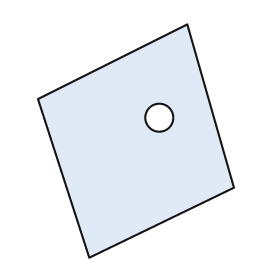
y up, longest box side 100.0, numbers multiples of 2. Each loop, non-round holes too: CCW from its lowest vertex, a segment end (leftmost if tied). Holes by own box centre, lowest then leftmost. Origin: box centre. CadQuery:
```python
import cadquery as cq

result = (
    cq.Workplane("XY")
    .moveTo(-20.0, -50.0)
    .lineTo(42.0, -20.0)
    .lineTo(22.0, 50.0)
    .lineTo(-42.0, 18.0)
    .close()
    .moveTo(10.0, 10.0)
    .circle(6.0)
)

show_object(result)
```